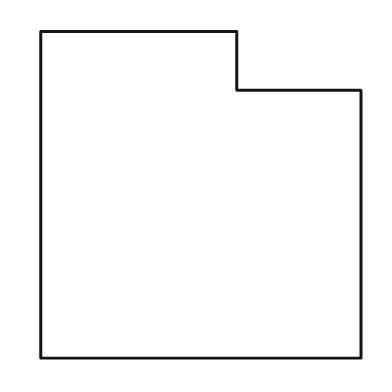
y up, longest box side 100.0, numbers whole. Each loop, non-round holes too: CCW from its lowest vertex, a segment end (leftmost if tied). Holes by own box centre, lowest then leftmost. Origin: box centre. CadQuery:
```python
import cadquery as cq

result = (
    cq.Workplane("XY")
    .moveTo(-49.0, -50.0)
    .lineTo(49.0, -50.0)
    .lineTo(49.0, 32.0)
    .lineTo(11.0, 32.0)
    .lineTo(11.0, 50.0)
    .lineTo(-49.0, 50.0)
    .close()
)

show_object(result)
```